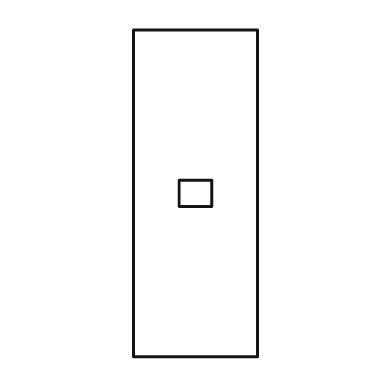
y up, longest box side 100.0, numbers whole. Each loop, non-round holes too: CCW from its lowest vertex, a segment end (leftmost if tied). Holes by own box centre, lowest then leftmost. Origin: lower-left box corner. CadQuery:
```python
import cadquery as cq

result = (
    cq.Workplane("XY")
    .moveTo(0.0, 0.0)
    .lineTo(38.0, 0.0)
    .lineTo(38.0, 100.0)
    .lineTo(0.0, 100.0)
    .close()
    .moveTo(14.0, 46.0)
    .lineTo(24.0, 46.0)
    .lineTo(24.0, 54.0)
    .lineTo(14.0, 54.0)
    .close()
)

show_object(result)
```